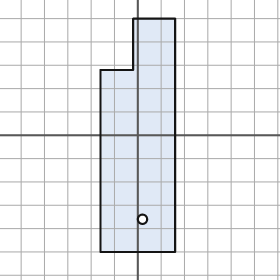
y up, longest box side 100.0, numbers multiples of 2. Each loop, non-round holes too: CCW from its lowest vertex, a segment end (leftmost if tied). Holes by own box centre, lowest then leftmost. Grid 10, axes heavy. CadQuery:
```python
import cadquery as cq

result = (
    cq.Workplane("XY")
    .moveTo(-16.0, -50.0)
    .lineTo(16.0, -50.0)
    .lineTo(16.0, 50.0)
    .lineTo(-2.0, 50.0)
    .lineTo(-2.0, 28.0)
    .lineTo(-16.0, 28.0)
    .close()
    .moveTo(2.0, -36.0)
    .circle(2.0)
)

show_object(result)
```